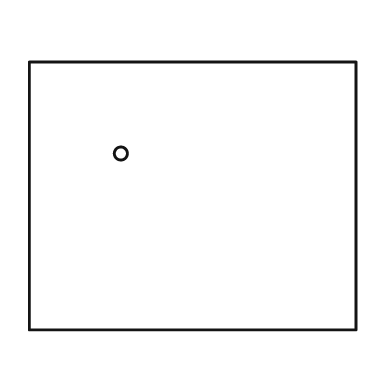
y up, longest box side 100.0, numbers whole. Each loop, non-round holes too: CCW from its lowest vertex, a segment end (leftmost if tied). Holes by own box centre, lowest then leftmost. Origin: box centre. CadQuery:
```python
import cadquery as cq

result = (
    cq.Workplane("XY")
    .moveTo(-50.0, -41.0)
    .lineTo(50.0, -41.0)
    .lineTo(50.0, 41.0)
    .lineTo(-50.0, 41.0)
    .close()
    .moveTo(-22.0, 13.0)
    .circle(2.0)
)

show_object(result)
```